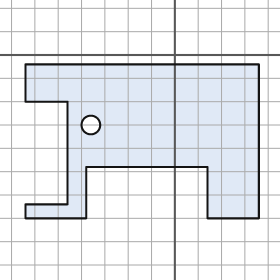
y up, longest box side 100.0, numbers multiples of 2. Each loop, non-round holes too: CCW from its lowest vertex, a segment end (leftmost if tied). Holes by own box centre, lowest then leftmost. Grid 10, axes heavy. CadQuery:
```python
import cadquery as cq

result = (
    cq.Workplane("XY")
    .moveTo(-64.0, -70.0)
    .lineTo(-38.0, -70.0)
    .lineTo(-38.0, -48.0)
    .lineTo(14.0, -48.0)
    .lineTo(14.0, -70.0)
    .lineTo(36.0, -70.0)
    .lineTo(36.0, -4.0)
    .lineTo(-64.0, -4.0)
    .lineTo(-64.0, -20.0)
    .lineTo(-46.0, -20.0)
    .lineTo(-46.0, -64.0)
    .lineTo(-64.0, -64.0)
    .close()
    .moveTo(-36.0, -30.0)
    .circle(4.0)
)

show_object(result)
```